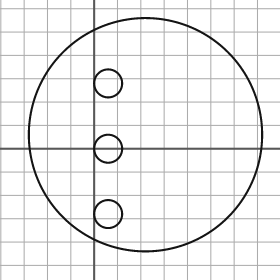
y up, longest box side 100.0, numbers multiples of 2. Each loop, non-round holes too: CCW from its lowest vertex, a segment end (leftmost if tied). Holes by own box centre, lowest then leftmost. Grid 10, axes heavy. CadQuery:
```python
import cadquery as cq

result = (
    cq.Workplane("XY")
    .moveTo(22.0, 6.0)
    .circle(50.0)
    .moveTo(6.0, -28.0)
    .circle(6.0)
    .moveTo(6.0, 0.0)
    .circle(6.0)
    .moveTo(6.0, 28.0)
    .circle(6.0)
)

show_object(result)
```